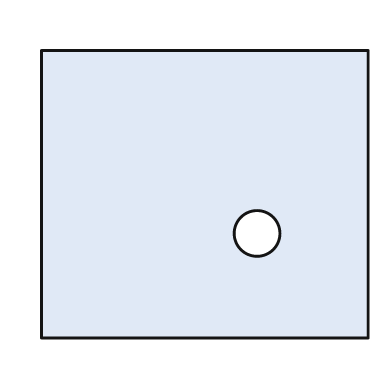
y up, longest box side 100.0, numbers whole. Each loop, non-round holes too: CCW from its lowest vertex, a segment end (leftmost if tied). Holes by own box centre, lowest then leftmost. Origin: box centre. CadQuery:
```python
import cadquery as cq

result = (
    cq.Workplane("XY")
    .moveTo(-50.0, -44.0)
    .lineTo(50.0, -44.0)
    .lineTo(50.0, 44.0)
    .lineTo(-50.0, 44.0)
    .close()
    .moveTo(16.0, -12.0)
    .circle(7.0)
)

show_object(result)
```